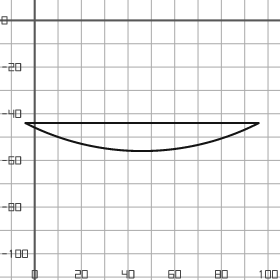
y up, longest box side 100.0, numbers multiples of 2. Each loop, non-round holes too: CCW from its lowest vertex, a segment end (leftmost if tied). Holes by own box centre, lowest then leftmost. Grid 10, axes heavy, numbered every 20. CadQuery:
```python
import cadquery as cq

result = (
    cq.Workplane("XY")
    .moveTo(-4.0, -44.0)
    .threePointArc((46.0, -56.0), (96.0, -44.0))
    .close()
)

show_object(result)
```